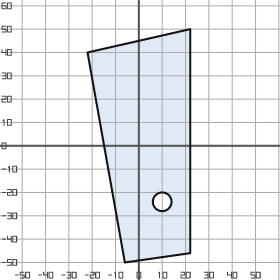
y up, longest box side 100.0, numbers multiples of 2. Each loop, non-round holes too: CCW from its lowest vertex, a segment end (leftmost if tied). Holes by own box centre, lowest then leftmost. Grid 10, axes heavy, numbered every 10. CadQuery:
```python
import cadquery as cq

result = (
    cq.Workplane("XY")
    .moveTo(-6.0, -50.0)
    .lineTo(22.0, -46.0)
    .lineTo(22.0, 50.0)
    .lineTo(-22.0, 40.0)
    .close()
    .moveTo(10.0, -24.0)
    .circle(4.0)
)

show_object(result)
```